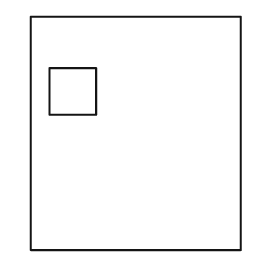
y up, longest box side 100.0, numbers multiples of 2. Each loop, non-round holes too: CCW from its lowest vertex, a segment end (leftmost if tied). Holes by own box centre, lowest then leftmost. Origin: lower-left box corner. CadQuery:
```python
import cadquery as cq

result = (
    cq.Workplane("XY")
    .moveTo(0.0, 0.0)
    .lineTo(90.0, 0.0)
    .lineTo(90.0, 100.0)
    .lineTo(0.0, 100.0)
    .close()
    .moveTo(8.0, 58.0)
    .lineTo(28.0, 58.0)
    .lineTo(28.0, 78.0)
    .lineTo(8.0, 78.0)
    .close()
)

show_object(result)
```